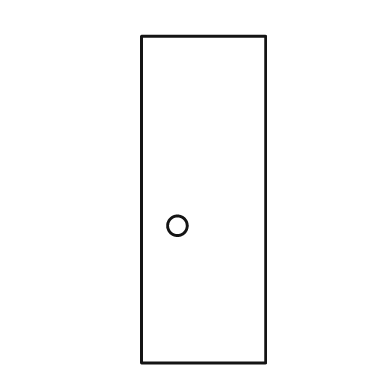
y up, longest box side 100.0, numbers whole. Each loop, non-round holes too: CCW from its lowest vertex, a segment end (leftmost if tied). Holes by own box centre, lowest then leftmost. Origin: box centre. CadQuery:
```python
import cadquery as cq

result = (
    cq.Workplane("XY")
    .moveTo(-19.0, -50.0)
    .lineTo(19.0, -50.0)
    .lineTo(19.0, 50.0)
    .lineTo(-19.0, 50.0)
    .close()
    .moveTo(-8.0, -8.0)
    .circle(3.0)
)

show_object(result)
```